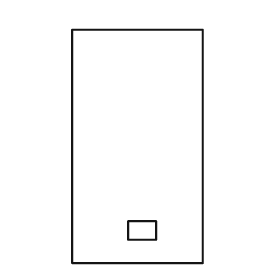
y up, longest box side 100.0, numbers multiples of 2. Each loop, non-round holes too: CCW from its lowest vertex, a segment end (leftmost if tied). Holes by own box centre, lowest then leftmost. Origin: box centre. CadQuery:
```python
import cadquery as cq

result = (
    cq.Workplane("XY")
    .moveTo(-28.0, -50.0)
    .lineTo(28.0, -50.0)
    .lineTo(28.0, 50.0)
    .lineTo(-28.0, 50.0)
    .close()
    .moveTo(-4.0, -40.0)
    .lineTo(8.0, -40.0)
    .lineTo(8.0, -32.0)
    .lineTo(-4.0, -32.0)
    .close()
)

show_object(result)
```